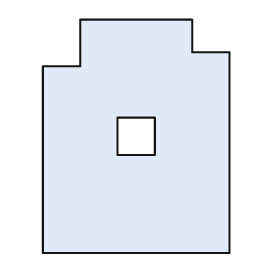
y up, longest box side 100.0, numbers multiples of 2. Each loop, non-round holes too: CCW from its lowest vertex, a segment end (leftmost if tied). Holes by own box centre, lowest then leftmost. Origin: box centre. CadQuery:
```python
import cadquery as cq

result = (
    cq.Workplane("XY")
    .moveTo(-40.0, -50.0)
    .lineTo(40.0, -50.0)
    .lineTo(40.0, 36.0)
    .lineTo(24.0, 36.0)
    .lineTo(24.0, 50.0)
    .lineTo(-24.0, 50.0)
    .lineTo(-24.0, 30.0)
    .lineTo(-40.0, 30.0)
    .close()
    .moveTo(-8.0, -8.0)
    .lineTo(8.0, -8.0)
    .lineTo(8.0, 8.0)
    .lineTo(-8.0, 8.0)
    .close()
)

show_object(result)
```